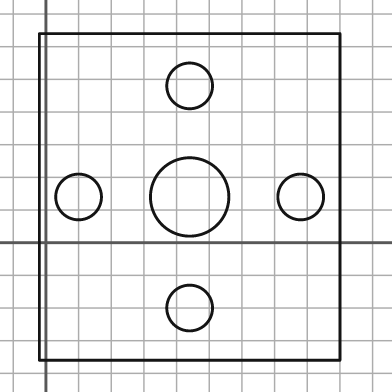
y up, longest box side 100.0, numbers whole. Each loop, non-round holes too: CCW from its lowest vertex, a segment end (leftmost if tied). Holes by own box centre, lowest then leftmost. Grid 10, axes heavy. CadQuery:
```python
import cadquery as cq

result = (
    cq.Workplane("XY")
    .moveTo(-2.0, -36.0)
    .lineTo(90.0, -36.0)
    .lineTo(90.0, 64.0)
    .lineTo(-2.0, 64.0)
    .close()
    .moveTo(44.0, -20.0)
    .circle(7.0)
    .moveTo(10.0, 14.0)
    .circle(7.0)
    .moveTo(44.0, 14.0)
    .circle(12.0)
    .moveTo(78.0, 14.0)
    .circle(7.0)
    .moveTo(44.0, 48.0)
    .circle(7.0)
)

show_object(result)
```